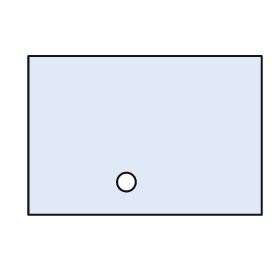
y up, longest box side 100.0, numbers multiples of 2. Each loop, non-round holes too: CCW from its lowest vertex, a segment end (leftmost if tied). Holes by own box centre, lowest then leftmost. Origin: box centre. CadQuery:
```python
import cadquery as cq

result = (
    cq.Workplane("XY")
    .moveTo(-50.0, -34.0)
    .lineTo(50.0, -34.0)
    .lineTo(50.0, 34.0)
    .lineTo(-50.0, 34.0)
    .close()
    .moveTo(-8.0, -20.0)
    .circle(4.0)
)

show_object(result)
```